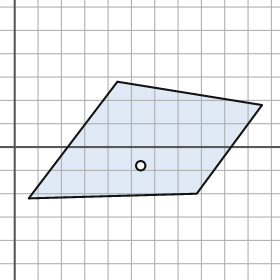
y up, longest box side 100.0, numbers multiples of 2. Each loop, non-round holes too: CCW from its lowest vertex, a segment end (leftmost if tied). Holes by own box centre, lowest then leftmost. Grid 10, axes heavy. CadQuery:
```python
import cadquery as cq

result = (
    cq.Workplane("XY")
    .moveTo(6.0, -22.0)
    .lineTo(78.0, -20.0)
    .lineTo(106.0, 18.0)
    .lineTo(44.0, 28.0)
    .close()
    .moveTo(54.0, -8.0)
    .circle(2.0)
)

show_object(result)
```